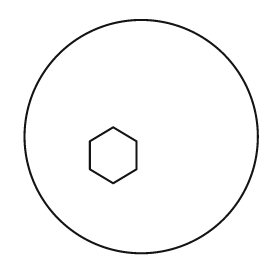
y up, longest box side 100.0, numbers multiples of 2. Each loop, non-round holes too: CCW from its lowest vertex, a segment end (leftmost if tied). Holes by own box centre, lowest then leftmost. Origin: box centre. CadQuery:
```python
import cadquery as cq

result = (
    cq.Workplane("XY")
    .moveTo(0.0, 0.0)
    .circle(50.0)
    .moveTo(-12.0, -20.0)
    .lineTo(-2.0, -14.0)
    .lineTo(-2.0, -2.0)
    .lineTo(-12.0, 4.0)
    .lineTo(-22.0, -2.0)
    .lineTo(-22.0, -14.0)
    .close()
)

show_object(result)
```